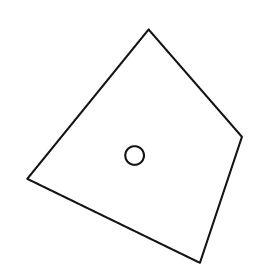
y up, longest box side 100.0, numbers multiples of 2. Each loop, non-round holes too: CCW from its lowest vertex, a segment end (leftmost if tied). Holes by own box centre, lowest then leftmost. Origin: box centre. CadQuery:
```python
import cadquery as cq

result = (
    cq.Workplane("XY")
    .moveTo(28.0, -50.0)
    .lineTo(46.0, 4.0)
    .lineTo(6.0, 50.0)
    .lineTo(-46.0, -14.0)
    .close()
    .moveTo(0.0, -4.0)
    .circle(4.0)
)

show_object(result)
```